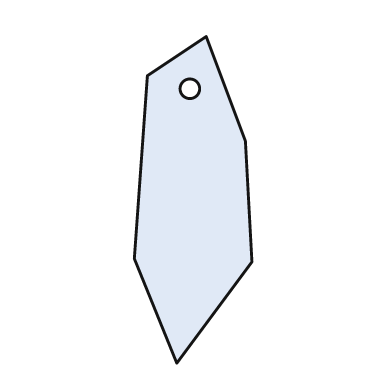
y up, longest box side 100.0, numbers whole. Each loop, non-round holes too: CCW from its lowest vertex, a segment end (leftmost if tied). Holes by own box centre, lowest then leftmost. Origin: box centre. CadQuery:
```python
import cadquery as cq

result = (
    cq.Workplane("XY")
    .moveTo(-5.0, -50.0)
    .lineTo(18.0, -19.0)
    .lineTo(16.0, 18.0)
    .lineTo(4.0, 50.0)
    .lineTo(-14.0, 38.0)
    .lineTo(-18.0, -18.0)
    .close()
    .moveTo(-1.0, 34.0)
    .circle(3.0)
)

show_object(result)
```